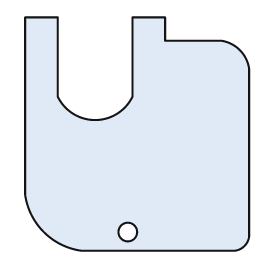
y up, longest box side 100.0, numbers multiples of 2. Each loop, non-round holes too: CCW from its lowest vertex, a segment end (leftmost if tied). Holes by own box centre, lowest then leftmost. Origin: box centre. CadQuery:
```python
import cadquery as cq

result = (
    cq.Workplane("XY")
    .moveTo(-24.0, -50.0)
    .lineTo(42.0, -50.0)
    .threePointArc((46.0, -48.0), (48.0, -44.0))
    .lineTo(48.0, 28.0)
    .threePointArc((44.0, 36.0), (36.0, 40.0))
    .lineTo(12.0, 40.0)
    .lineTo(12.0, 50.0)
    .lineTo(-2.0, 50.0)
    .lineTo(-2.0, 16.0)
    .threePointArc((-18.0, 6.0), (-34.0, 16.0))
    .lineTo(-34.0, 50.0)
    .lineTo(-48.0, 50.0)
    .lineTo(-48.0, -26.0)
    .threePointArc((-40.0, -42.0), (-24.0, -50.0))
    .close()
    .moveTo(-4.0, -42.0)
    .circle(4.0)
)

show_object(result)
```